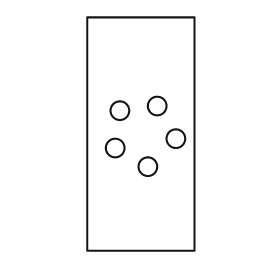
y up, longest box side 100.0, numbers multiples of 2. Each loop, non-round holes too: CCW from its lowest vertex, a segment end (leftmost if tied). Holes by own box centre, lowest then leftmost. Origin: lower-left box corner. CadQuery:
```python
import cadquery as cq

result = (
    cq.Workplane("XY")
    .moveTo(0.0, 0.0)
    .lineTo(46.0, 0.0)
    .lineTo(46.0, 100.0)
    .lineTo(0.0, 100.0)
    .close()
    .moveTo(26.0, 36.0)
    .circle(4.0)
    .moveTo(12.0, 44.0)
    .circle(4.0)
    .moveTo(38.0, 48.0)
    .circle(4.0)
    .moveTo(14.0, 60.0)
    .circle(4.0)
    .moveTo(30.0, 62.0)
    .circle(4.0)
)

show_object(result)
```